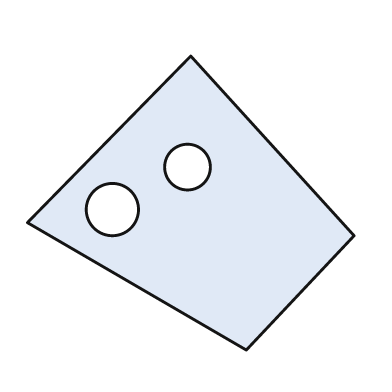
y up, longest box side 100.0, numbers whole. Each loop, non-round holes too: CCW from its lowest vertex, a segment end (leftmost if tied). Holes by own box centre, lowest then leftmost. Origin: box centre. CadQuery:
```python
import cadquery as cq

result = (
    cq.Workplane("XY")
    .moveTo(17.0, -45.0)
    .lineTo(50.0, -10.0)
    .lineTo(0.0, 45.0)
    .lineTo(-50.0, -6.0)
    .close()
    .moveTo(-24.0, -2.0)
    .circle(8.0)
    .moveTo(-1.0, 11.0)
    .circle(7.0)
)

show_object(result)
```